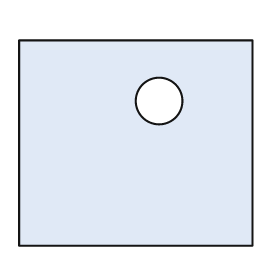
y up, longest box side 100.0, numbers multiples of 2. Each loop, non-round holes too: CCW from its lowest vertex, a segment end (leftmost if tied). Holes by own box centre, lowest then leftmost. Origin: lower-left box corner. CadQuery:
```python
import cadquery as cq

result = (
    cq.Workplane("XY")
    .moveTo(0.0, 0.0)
    .lineTo(100.0, 0.0)
    .lineTo(100.0, 88.0)
    .lineTo(0.0, 88.0)
    .close()
    .moveTo(60.0, 62.0)
    .circle(10.0)
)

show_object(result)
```